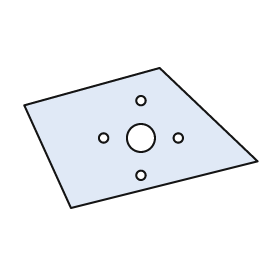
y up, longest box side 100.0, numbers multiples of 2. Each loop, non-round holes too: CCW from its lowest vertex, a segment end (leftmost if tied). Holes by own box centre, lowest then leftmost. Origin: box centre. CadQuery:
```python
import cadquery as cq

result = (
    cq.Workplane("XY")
    .moveTo(-30.0, -30.0)
    .lineTo(50.0, -10.0)
    .lineTo(8.0, 30.0)
    .lineTo(-50.0, 14.0)
    .close()
    .moveTo(0.0, -16.0)
    .circle(2.0)
    .moveTo(-16.0, 0.0)
    .circle(2.0)
    .moveTo(0.0, 0.0)
    .circle(6.0)
    .moveTo(16.0, 0.0)
    .circle(2.0)
    .moveTo(0.0, 16.0)
    .circle(2.0)
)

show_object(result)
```